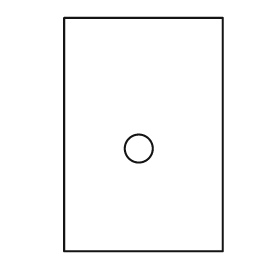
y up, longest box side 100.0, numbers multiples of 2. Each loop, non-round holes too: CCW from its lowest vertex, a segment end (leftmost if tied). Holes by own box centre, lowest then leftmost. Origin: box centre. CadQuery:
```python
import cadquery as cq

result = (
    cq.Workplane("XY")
    .moveTo(-34.0, -50.0)
    .lineTo(34.0, -50.0)
    .lineTo(34.0, 50.0)
    .lineTo(-34.0, 50.0)
    .close()
    .moveTo(-2.0, -6.0)
    .circle(6.0)
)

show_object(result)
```